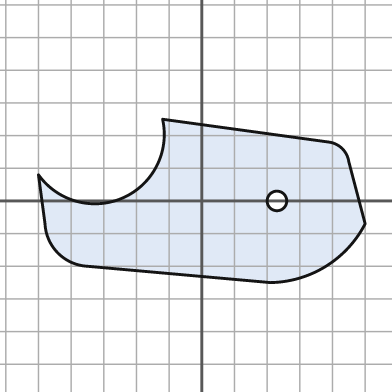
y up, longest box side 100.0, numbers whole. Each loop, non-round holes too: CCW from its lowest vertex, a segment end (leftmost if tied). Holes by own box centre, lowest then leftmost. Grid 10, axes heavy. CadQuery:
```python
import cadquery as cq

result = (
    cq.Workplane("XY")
    .moveTo(21.0, -25.0)
    .threePointArc((38.0, -20.0), (50.0, -7.0))
    .lineTo(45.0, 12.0)
    .threePointArc((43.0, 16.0), (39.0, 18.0))
    .lineTo(-12.0, 25.0)
    .threePointArc((-24.0, 1.0), (-50.0, 8.0))
    .lineTo(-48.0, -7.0)
    .threePointArc((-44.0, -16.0), (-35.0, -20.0))
    .close()
    .moveTo(23.0, 0.0)
    .circle(3.0)
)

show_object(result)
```